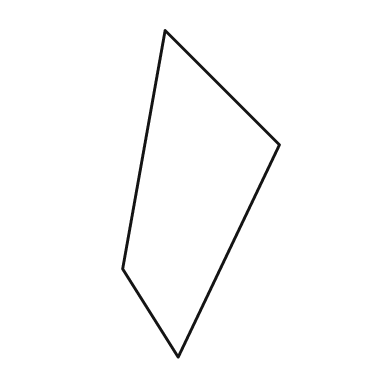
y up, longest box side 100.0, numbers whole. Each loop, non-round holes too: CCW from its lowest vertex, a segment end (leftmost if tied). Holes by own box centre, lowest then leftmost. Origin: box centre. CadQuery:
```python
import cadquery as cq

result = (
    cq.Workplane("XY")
    .moveTo(-7.0, -50.0)
    .lineTo(24.0, 15.0)
    .lineTo(-11.0, 50.0)
    .lineTo(-24.0, -23.0)
    .close()
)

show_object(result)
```